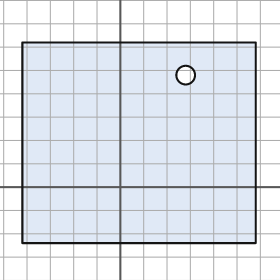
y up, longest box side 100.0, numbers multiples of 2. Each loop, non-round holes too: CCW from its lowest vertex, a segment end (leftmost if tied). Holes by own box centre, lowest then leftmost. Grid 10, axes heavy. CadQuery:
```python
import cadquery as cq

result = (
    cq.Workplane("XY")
    .moveTo(-42.0, -24.0)
    .lineTo(58.0, -24.0)
    .lineTo(58.0, 62.0)
    .lineTo(-42.0, 62.0)
    .close()
    .moveTo(28.0, 48.0)
    .circle(4.0)
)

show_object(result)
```